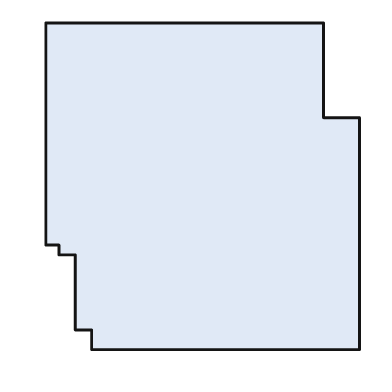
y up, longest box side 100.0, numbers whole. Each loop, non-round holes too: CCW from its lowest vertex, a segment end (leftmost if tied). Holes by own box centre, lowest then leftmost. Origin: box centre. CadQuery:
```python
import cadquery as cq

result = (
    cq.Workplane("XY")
    .moveTo(-34.0, -50.0)
    .lineTo(48.0, -50.0)
    .lineTo(48.0, 21.0)
    .lineTo(37.0, 21.0)
    .lineTo(37.0, 50.0)
    .lineTo(-48.0, 50.0)
    .lineTo(-48.0, -18.0)
    .lineTo(-44.0, -18.0)
    .lineTo(-44.0, -21.0)
    .lineTo(-39.0, -21.0)
    .lineTo(-39.0, -44.0)
    .lineTo(-34.0, -44.0)
    .close()
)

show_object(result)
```